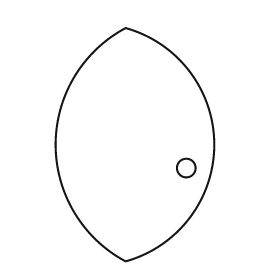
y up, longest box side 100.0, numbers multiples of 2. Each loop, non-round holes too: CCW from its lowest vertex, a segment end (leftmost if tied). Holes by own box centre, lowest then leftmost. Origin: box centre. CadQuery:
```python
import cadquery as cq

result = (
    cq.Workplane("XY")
    .moveTo(-4.0, -50.0)
    .threePointArc((34.0, 0.0), (-4.0, 50.0))
    .threePointArc((-34.0, 0.0), (-4.0, -50.0))
    .close()
    .moveTo(22.0, -10.0)
    .circle(4.0)
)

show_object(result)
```